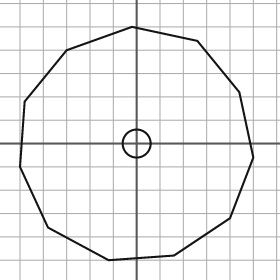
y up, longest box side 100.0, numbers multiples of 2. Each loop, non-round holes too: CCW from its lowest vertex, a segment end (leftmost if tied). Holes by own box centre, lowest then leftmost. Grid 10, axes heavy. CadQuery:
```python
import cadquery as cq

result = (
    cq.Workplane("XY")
    .moveTo(-12.0, -50.0)
    .lineTo(16.0, -48.0)
    .lineTo(40.0, -32.0)
    .lineTo(50.0, -6.0)
    .lineTo(44.0, 22.0)
    .lineTo(26.0, 44.0)
    .lineTo(-2.0, 50.0)
    .lineTo(-30.0, 40.0)
    .lineTo(-48.0, 18.0)
    .lineTo(-50.0, -10.0)
    .lineTo(-38.0, -36.0)
    .close()
    .moveTo(0.0, 0.0)
    .circle(6.0)
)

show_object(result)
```